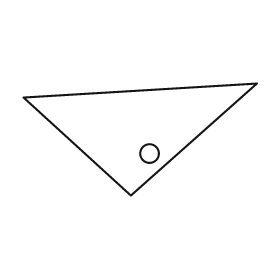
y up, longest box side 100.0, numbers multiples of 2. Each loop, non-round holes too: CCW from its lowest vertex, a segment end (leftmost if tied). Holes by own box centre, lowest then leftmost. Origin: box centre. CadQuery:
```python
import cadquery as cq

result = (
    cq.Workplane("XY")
    .moveTo(-4.0, -24.0)
    .lineTo(50.0, 24.0)
    .lineTo(-50.0, 18.0)
    .close()
    .moveTo(4.0, -6.0)
    .circle(4.0)
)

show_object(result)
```